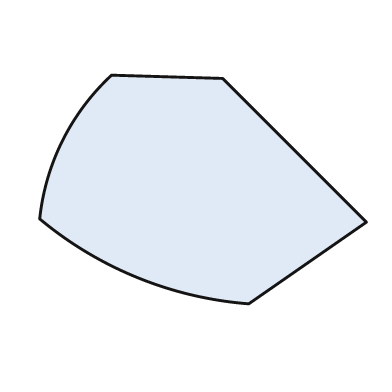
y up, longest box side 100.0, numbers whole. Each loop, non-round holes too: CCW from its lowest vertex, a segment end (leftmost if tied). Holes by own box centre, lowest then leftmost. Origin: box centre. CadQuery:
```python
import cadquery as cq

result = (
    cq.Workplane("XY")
    .moveTo(14.0, -35.0)
    .lineTo(50.0, -10.0)
    .lineTo(6.0, 34.0)
    .lineTo(-28.0, 35.0)
    .threePointArc((-43.0, 15.0), (-50.0, -9.0))
    .threePointArc((-20.0, -27.0), (14.0, -35.0))
    .close()
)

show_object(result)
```